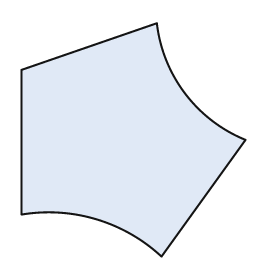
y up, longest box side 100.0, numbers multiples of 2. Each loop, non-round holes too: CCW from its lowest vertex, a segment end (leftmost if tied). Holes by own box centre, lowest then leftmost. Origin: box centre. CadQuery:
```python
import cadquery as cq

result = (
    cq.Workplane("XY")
    .moveTo(12.0, -50.0)
    .lineTo(48.0, 0.0)
    .threePointArc((22.0, 20.0), (10.0, 50.0))
    .lineTo(-48.0, 30.0)
    .lineTo(-48.0, -32.0)
    .threePointArc((-16.0, -34.0), (12.0, -50.0))
    .close()
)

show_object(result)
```